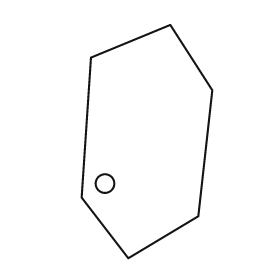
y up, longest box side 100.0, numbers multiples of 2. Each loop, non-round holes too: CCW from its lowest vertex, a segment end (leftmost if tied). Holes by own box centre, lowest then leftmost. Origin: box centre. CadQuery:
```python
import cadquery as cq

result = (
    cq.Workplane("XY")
    .moveTo(-8.0, -50.0)
    .lineTo(22.0, -32.0)
    .lineTo(28.0, 22.0)
    .lineTo(10.0, 50.0)
    .lineTo(-24.0, 36.0)
    .lineTo(-28.0, -24.0)
    .close()
    .moveTo(-18.0, -18.0)
    .circle(4.0)
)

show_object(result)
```